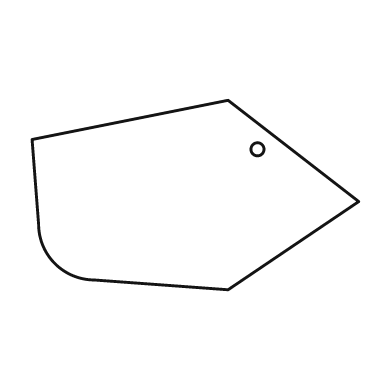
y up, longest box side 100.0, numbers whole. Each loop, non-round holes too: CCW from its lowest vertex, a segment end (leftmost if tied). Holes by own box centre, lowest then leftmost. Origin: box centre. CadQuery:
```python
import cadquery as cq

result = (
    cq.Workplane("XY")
    .moveTo(10.0, -29.0)
    .lineTo(50.0, -2.0)
    .lineTo(10.0, 29.0)
    .lineTo(-50.0, 17.0)
    .lineTo(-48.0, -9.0)
    .threePointArc((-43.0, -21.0), (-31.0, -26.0))
    .close()
    .moveTo(19.0, 14.0)
    .circle(2.0)
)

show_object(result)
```